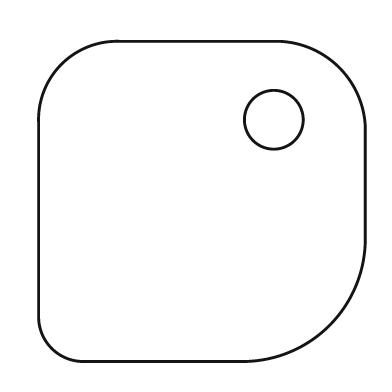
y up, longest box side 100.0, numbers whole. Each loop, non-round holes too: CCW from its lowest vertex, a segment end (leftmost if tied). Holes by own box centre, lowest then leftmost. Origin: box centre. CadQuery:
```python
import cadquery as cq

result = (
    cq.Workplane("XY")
    .moveTo(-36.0, -49.0)
    .lineTo(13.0, -49.0)
    .threePointArc((39.0, -38.0), (50.0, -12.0))
    .lineTo(50.0, 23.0)
    .threePointArc((42.0, 41.0), (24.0, 49.0))
    .lineTo(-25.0, 49.0)
    .threePointArc((-43.0, 42.0), (-50.0, 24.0))
    .lineTo(-50.0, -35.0)
    .threePointArc((-46.0, -45.0), (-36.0, -49.0))
    .close()
    .moveTo(22.0, 25.0)
    .circle(9.0)
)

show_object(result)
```